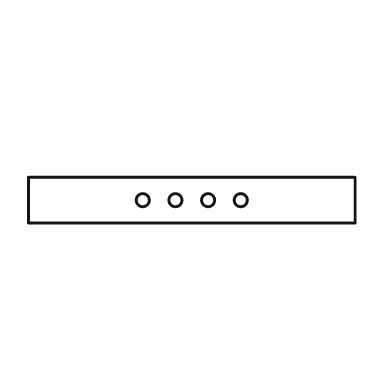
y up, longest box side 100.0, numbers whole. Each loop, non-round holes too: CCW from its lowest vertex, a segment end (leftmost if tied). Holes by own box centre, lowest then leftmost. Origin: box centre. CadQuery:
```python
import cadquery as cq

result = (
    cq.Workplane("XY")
    .moveTo(-50.0, -7.0)
    .lineTo(50.0, -7.0)
    .lineTo(50.0, 7.0)
    .lineTo(-50.0, 7.0)
    .close()
    .moveTo(-15.0, 0.0)
    .circle(2.0)
    .moveTo(-5.0, 0.0)
    .circle(2.0)
    .moveTo(5.0, 0.0)
    .circle(2.0)
    .moveTo(15.0, 0.0)
    .circle(2.0)
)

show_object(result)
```